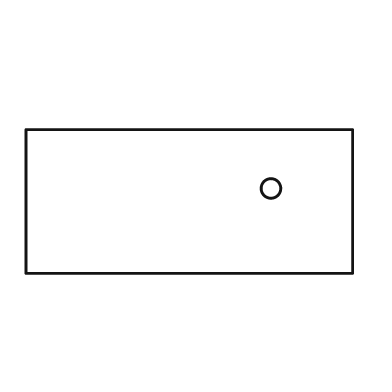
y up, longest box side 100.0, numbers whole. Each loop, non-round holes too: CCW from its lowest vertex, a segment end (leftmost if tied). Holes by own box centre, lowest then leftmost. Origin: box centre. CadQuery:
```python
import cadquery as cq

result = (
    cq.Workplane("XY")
    .moveTo(-50.0, -22.0)
    .lineTo(50.0, -22.0)
    .lineTo(50.0, 22.0)
    .lineTo(-50.0, 22.0)
    .close()
    .moveTo(25.0, 4.0)
    .circle(3.0)
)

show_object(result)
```